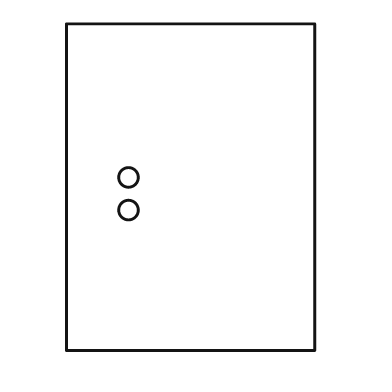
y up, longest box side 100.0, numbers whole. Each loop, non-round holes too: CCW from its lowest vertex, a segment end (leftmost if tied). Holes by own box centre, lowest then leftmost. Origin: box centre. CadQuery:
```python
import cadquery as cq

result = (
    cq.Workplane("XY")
    .moveTo(-38.0, -50.0)
    .lineTo(38.0, -50.0)
    .lineTo(38.0, 50.0)
    .lineTo(-38.0, 50.0)
    .close()
    .moveTo(-19.0, -7.0)
    .circle(3.0)
    .moveTo(-19.0, 3.0)
    .circle(3.0)
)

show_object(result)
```